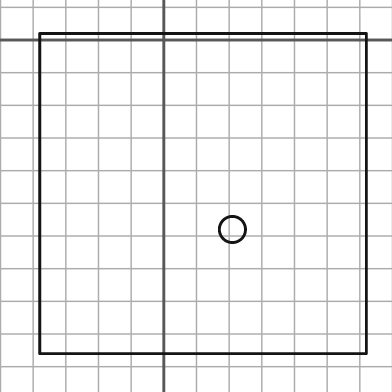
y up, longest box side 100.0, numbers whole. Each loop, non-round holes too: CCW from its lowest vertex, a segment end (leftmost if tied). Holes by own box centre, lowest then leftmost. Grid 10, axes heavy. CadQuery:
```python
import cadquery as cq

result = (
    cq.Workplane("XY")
    .moveTo(-38.0, -96.0)
    .lineTo(62.0, -96.0)
    .lineTo(62.0, 2.0)
    .lineTo(-38.0, 2.0)
    .close()
    .moveTo(21.0, -58.0)
    .circle(4.0)
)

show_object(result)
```